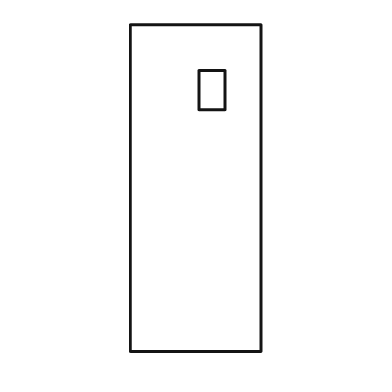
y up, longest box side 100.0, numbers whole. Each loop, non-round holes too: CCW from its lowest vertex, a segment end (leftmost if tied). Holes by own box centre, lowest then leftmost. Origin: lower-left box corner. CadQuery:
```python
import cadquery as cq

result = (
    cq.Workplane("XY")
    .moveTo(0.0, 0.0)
    .lineTo(40.0, 0.0)
    .lineTo(40.0, 100.0)
    .lineTo(0.0, 100.0)
    .close()
    .moveTo(21.0, 74.0)
    .lineTo(29.0, 74.0)
    .lineTo(29.0, 86.0)
    .lineTo(21.0, 86.0)
    .close()
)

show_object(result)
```